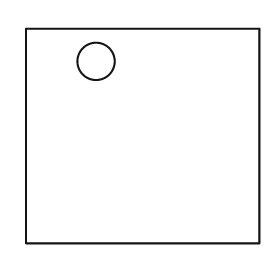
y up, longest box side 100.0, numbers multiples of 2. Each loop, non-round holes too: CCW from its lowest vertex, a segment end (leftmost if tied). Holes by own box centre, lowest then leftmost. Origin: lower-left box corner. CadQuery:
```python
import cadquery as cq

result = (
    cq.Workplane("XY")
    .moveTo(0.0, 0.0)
    .lineTo(100.0, 0.0)
    .lineTo(100.0, 92.0)
    .lineTo(0.0, 92.0)
    .close()
    .moveTo(30.0, 78.0)
    .circle(8.0)
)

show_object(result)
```